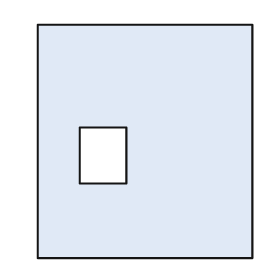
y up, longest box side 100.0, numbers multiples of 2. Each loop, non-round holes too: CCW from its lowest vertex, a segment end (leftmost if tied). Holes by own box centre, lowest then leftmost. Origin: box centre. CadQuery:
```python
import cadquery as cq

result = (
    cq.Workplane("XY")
    .moveTo(-46.0, -50.0)
    .lineTo(46.0, -50.0)
    .lineTo(46.0, 50.0)
    .lineTo(-46.0, 50.0)
    .close()
    .moveTo(-28.0, -18.0)
    .lineTo(-8.0, -18.0)
    .lineTo(-8.0, 6.0)
    .lineTo(-28.0, 6.0)
    .close()
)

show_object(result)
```